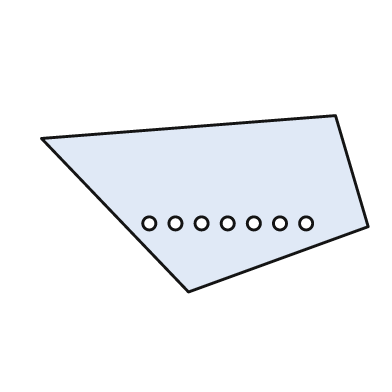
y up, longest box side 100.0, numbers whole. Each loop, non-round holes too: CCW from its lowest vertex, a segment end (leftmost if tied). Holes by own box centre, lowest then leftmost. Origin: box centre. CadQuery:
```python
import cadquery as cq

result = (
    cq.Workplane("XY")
    .moveTo(-5.0, -27.0)
    .lineTo(50.0, -7.0)
    .lineTo(40.0, 27.0)
    .lineTo(-50.0, 20.0)
    .close()
    .moveTo(-17.0, -6.0)
    .circle(2.0)
    .moveTo(-9.0, -6.0)
    .circle(2.0)
    .moveTo(-1.0, -6.0)
    .circle(2.0)
    .moveTo(7.0, -6.0)
    .circle(2.0)
    .moveTo(15.0, -6.0)
    .circle(2.0)
    .moveTo(23.0, -6.0)
    .circle(2.0)
    .moveTo(31.0, -6.0)
    .circle(2.0)
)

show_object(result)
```